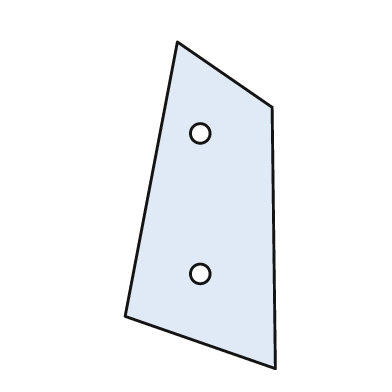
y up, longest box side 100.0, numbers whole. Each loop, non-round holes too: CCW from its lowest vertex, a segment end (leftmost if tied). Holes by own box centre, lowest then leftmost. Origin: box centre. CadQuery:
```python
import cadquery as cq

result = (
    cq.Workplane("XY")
    .moveTo(23.0, -50.0)
    .lineTo(22.0, 30.0)
    .lineTo(-7.0, 50.0)
    .lineTo(-23.0, -34.0)
    .close()
    .moveTo(0.0, -21.0)
    .circle(3.0)
    .moveTo(0.0, 22.0)
    .circle(3.0)
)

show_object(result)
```